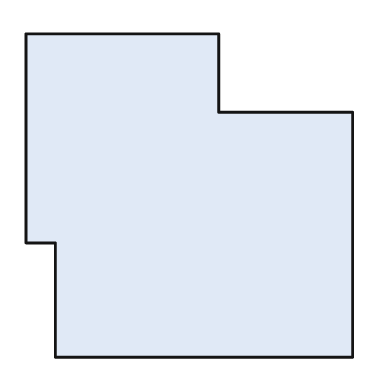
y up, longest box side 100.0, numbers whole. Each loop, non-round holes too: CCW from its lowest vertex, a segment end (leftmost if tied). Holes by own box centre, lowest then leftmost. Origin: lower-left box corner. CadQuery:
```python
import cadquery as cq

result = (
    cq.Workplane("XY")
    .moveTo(9.0, 0.0)
    .lineTo(100.0, 0.0)
    .lineTo(100.0, 75.0)
    .lineTo(59.0, 75.0)
    .lineTo(59.0, 99.0)
    .lineTo(0.0, 99.0)
    .lineTo(0.0, 35.0)
    .lineTo(9.0, 35.0)
    .close()
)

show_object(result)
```